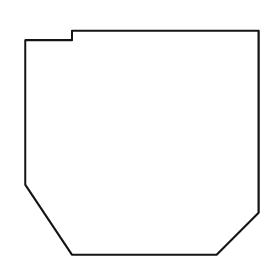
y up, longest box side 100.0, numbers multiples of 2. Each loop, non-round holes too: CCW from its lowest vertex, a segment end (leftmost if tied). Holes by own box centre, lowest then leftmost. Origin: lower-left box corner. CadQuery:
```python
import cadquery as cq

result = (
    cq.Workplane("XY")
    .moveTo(20.0, 0.0)
    .lineTo(82.0, 0.0)
    .lineTo(100.0, 18.0)
    .lineTo(100.0, 96.0)
    .lineTo(20.0, 96.0)
    .lineTo(20.0, 92.0)
    .lineTo(0.0, 92.0)
    .lineTo(0.0, 30.0)
    .close()
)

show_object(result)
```